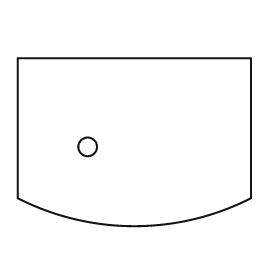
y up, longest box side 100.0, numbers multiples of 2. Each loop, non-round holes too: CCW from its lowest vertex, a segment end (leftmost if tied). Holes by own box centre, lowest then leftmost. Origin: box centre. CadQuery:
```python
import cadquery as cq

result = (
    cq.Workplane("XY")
    .moveTo(-50.0, -24.0)
    .threePointArc((0.0, -36.0), (50.0, -24.0))
    .lineTo(50.0, 36.0)
    .lineTo(-50.0, 36.0)
    .close()
    .moveTo(-20.0, -2.0)
    .circle(4.0)
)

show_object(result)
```